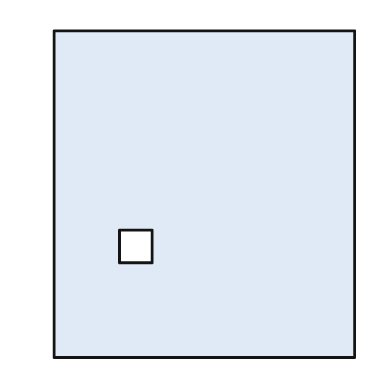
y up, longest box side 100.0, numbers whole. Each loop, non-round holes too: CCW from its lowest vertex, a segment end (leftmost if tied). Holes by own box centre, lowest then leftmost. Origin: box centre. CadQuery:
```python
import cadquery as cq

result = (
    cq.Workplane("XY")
    .moveTo(-46.0, -50.0)
    .lineTo(46.0, -50.0)
    .lineTo(46.0, 50.0)
    .lineTo(-46.0, 50.0)
    .close()
    .moveTo(-26.0, -21.0)
    .lineTo(-16.0, -21.0)
    .lineTo(-16.0, -11.0)
    .lineTo(-26.0, -11.0)
    .close()
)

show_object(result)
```